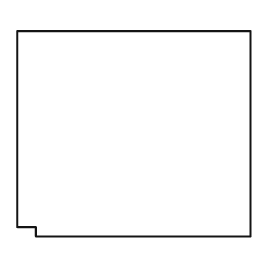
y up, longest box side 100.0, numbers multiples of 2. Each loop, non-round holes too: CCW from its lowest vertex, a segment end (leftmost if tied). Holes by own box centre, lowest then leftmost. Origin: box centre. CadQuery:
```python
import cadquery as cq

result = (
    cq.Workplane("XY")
    .moveTo(-42.0, -44.0)
    .lineTo(50.0, -44.0)
    .lineTo(50.0, 44.0)
    .lineTo(-50.0, 44.0)
    .lineTo(-50.0, -40.0)
    .lineTo(-42.0, -40.0)
    .close()
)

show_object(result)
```